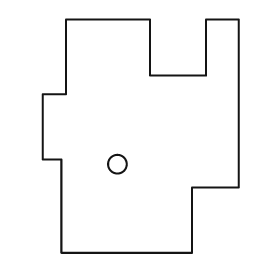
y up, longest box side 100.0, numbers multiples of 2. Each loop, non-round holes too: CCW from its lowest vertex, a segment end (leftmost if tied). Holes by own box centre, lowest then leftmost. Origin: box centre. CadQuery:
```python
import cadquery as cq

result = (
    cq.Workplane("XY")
    .moveTo(-34.0, -50.0)
    .lineTo(22.0, -50.0)
    .lineTo(22.0, -22.0)
    .lineTo(42.0, -22.0)
    .lineTo(42.0, 50.0)
    .lineTo(28.0, 50.0)
    .lineTo(28.0, 26.0)
    .lineTo(4.0, 26.0)
    .lineTo(4.0, 50.0)
    .lineTo(-32.0, 50.0)
    .lineTo(-32.0, 18.0)
    .lineTo(-42.0, 18.0)
    .lineTo(-42.0, -10.0)
    .lineTo(-34.0, -10.0)
    .close()
    .moveTo(-10.0, -12.0)
    .circle(4.0)
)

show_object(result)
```